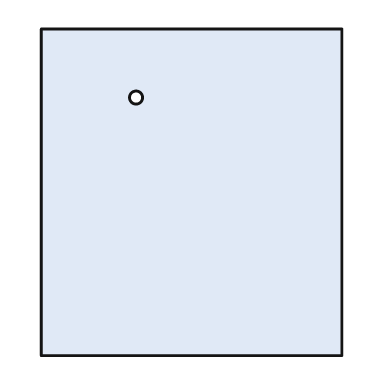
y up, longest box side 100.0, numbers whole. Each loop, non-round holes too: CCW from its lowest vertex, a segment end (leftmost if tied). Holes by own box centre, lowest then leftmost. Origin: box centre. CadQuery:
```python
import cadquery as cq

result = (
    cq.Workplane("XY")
    .moveTo(-46.0, -50.0)
    .lineTo(46.0, -50.0)
    .lineTo(46.0, 50.0)
    .lineTo(-46.0, 50.0)
    .close()
    .moveTo(-17.0, 29.0)
    .circle(2.0)
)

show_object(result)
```